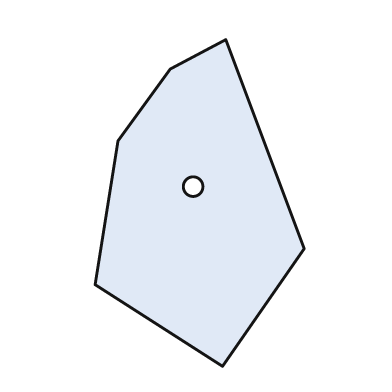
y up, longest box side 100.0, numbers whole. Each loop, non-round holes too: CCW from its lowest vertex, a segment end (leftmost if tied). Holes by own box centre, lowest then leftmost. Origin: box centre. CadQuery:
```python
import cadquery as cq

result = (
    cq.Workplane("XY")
    .moveTo(7.0, -50.0)
    .lineTo(32.0, -14.0)
    .lineTo(8.0, 50.0)
    .lineTo(-9.0, 41.0)
    .lineTo(-25.0, 19.0)
    .lineTo(-32.0, -25.0)
    .close()
    .moveTo(-2.0, 5.0)
    .circle(3.0)
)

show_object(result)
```